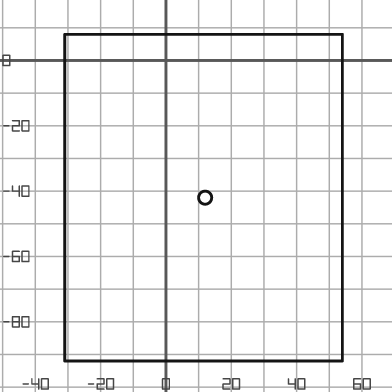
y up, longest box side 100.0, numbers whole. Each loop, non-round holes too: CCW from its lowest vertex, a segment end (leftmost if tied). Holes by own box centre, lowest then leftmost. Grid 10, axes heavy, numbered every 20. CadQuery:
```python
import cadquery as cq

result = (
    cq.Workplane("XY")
    .moveTo(-31.0, -92.0)
    .lineTo(54.0, -92.0)
    .lineTo(54.0, 8.0)
    .lineTo(-31.0, 8.0)
    .close()
    .moveTo(12.0, -42.0)
    .circle(2.0)
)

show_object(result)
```